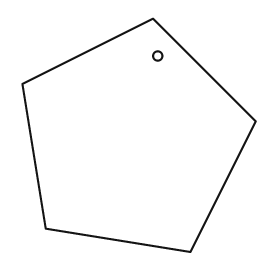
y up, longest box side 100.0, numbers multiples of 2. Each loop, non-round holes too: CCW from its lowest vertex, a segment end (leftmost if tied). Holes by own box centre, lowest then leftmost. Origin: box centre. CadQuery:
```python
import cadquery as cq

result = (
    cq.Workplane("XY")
    .moveTo(22.0, -50.0)
    .lineTo(50.0, 6.0)
    .lineTo(6.0, 50.0)
    .lineTo(-50.0, 22.0)
    .lineTo(-40.0, -40.0)
    .close()
    .moveTo(8.0, 34.0)
    .circle(2.0)
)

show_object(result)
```